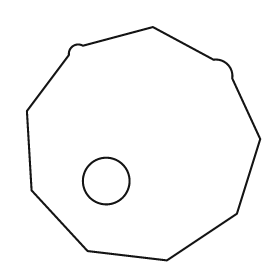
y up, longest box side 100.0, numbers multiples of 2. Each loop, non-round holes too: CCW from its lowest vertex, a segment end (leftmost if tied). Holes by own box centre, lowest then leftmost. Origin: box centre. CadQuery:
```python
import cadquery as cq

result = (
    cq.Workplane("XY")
    .moveTo(10.0, -50.0)
    .lineTo(40.0, -30.0)
    .lineTo(50.0, 2.0)
    .lineTo(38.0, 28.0)
    .threePointArc((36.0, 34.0), (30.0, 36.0))
    .lineTo(4.0, 50.0)
    .lineTo(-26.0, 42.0)
    .threePointArc((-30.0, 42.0), (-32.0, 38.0))
    .lineTo(-50.0, 14.0)
    .lineTo(-48.0, -20.0)
    .lineTo(-24.0, -46.0)
    .close()
    .moveTo(-16.0, -16.0)
    .circle(10.0)
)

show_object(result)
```